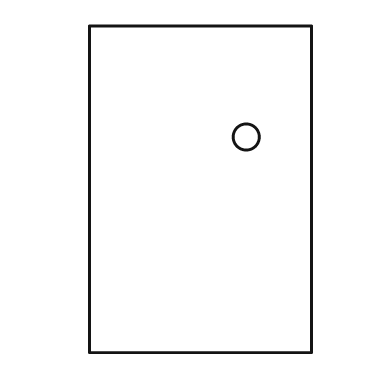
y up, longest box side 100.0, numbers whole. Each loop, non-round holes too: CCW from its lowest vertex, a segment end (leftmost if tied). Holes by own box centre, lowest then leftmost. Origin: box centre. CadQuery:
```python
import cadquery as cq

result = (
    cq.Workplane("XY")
    .moveTo(-34.0, -50.0)
    .lineTo(34.0, -50.0)
    .lineTo(34.0, 50.0)
    .lineTo(-34.0, 50.0)
    .close()
    .moveTo(14.0, 16.0)
    .circle(4.0)
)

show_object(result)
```